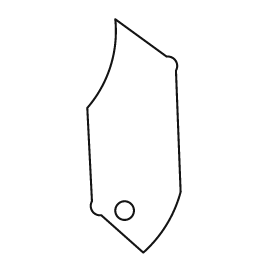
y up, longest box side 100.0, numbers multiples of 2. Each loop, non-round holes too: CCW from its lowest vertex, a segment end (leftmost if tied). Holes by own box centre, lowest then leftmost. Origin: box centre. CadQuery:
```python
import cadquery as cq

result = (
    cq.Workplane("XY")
    .moveTo(4.0, -50.0)
    .threePointArc((14.0, -38.0), (20.0, -24.0))
    .lineTo(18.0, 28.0)
    .threePointArc((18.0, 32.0), (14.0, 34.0))
    .lineTo(-8.0, 50.0)
    .threePointArc((-10.0, 30.0), (-20.0, 12.0))
    .lineTo(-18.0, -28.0)
    .threePointArc((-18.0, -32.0), (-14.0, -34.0))
    .close()
    .moveTo(-4.0, -32.0)
    .circle(4.0)
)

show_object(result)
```